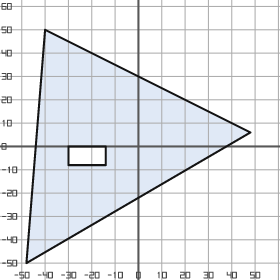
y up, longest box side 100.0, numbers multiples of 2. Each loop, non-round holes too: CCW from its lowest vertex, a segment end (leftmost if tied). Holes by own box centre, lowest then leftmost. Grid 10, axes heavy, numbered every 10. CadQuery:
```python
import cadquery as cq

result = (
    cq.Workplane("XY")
    .moveTo(-48.0, -50.0)
    .lineTo(48.0, 6.0)
    .lineTo(-40.0, 50.0)
    .close()
    .moveTo(-30.0, -8.0)
    .lineTo(-14.0, -8.0)
    .lineTo(-14.0, 0.0)
    .lineTo(-30.0, 0.0)
    .close()
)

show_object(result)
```